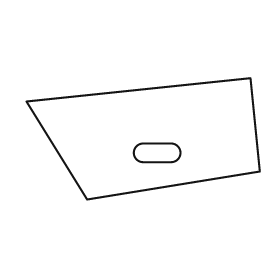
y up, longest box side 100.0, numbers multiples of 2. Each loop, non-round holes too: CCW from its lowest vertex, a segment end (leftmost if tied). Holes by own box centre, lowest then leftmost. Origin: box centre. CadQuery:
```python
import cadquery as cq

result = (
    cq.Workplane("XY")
    .moveTo(-24.0, -26.0)
    .lineTo(50.0, -14.0)
    .lineTo(46.0, 26.0)
    .lineTo(-50.0, 16.0)
    .close()
    .moveTo(0.0, -10.0)
    .lineTo(12.0, -10.0)
    .threePointArc((16.0, -6.0), (12.0, -2.0))
    .lineTo(0.0, -2.0)
    .threePointArc((-4.0, -6.0), (0.0, -10.0))
    .close()
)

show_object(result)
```